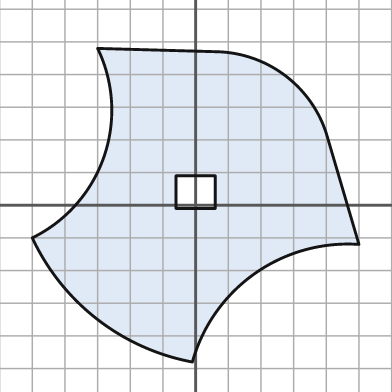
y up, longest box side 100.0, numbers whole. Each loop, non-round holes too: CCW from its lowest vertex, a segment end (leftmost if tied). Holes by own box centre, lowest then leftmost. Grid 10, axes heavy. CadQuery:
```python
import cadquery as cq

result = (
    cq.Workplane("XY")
    .moveTo(-1.0, -48.0)
    .threePointArc((18.0, -21.0), (50.0, -12.0))
    .lineTo(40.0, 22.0)
    .threePointArc((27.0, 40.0), (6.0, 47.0))
    .lineTo(-30.0, 48.0)
    .threePointArc((-28.0, 15.0), (-50.0, -10.0))
    .threePointArc((-30.0, -35.0), (-1.0, -48.0))
    .close()
    .moveTo(-6.0, -1.0)
    .lineTo(6.0, -1.0)
    .lineTo(6.0, 9.0)
    .lineTo(-6.0, 9.0)
    .close()
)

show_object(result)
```